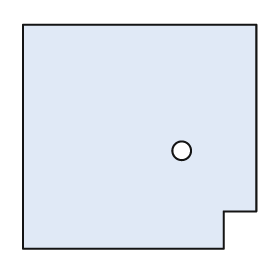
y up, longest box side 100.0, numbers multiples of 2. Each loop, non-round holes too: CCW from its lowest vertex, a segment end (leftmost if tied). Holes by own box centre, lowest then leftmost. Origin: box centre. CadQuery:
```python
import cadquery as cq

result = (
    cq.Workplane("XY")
    .moveTo(-50.0, -48.0)
    .lineTo(36.0, -48.0)
    .lineTo(36.0, -32.0)
    .lineTo(50.0, -32.0)
    .lineTo(50.0, 48.0)
    .lineTo(-50.0, 48.0)
    .close()
    .moveTo(18.0, -6.0)
    .circle(4.0)
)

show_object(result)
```